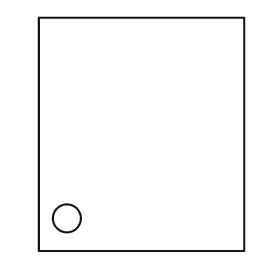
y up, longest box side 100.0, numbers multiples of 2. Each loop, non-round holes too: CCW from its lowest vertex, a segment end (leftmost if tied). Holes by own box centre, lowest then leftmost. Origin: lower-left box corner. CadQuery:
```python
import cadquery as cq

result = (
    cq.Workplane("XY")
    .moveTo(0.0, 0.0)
    .lineTo(88.0, 0.0)
    .lineTo(88.0, 100.0)
    .lineTo(0.0, 100.0)
    .close()
    .moveTo(12.0, 14.0)
    .circle(6.0)
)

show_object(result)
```